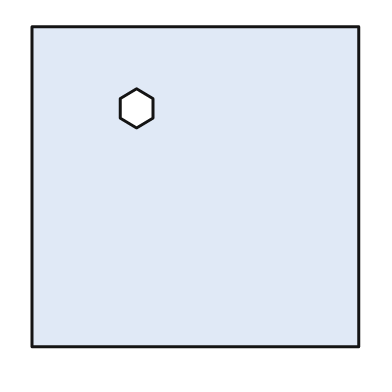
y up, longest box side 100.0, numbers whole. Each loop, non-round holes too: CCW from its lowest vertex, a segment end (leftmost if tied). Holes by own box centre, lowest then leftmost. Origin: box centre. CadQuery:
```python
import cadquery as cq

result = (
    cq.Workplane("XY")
    .moveTo(-50.0, -49.0)
    .lineTo(50.0, -49.0)
    .lineTo(50.0, 49.0)
    .lineTo(-50.0, 49.0)
    .close()
    .moveTo(-18.0, 18.0)
    .lineTo(-13.0, 21.0)
    .lineTo(-13.0, 27.0)
    .lineTo(-18.0, 30.0)
    .lineTo(-23.0, 27.0)
    .lineTo(-23.0, 21.0)
    .close()
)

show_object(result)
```